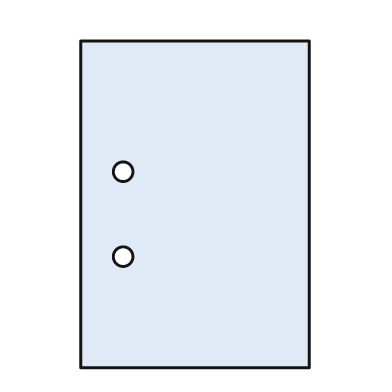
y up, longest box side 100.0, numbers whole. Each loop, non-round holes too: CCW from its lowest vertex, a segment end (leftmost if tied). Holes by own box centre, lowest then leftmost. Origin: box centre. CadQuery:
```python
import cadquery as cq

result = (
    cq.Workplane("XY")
    .moveTo(-35.0, -50.0)
    .lineTo(35.0, -50.0)
    .lineTo(35.0, 50.0)
    .lineTo(-35.0, 50.0)
    .close()
    .moveTo(-22.0, -16.0)
    .circle(3.0)
    .moveTo(-22.0, 10.0)
    .circle(3.0)
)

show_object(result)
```